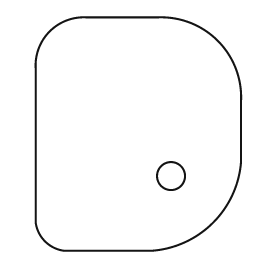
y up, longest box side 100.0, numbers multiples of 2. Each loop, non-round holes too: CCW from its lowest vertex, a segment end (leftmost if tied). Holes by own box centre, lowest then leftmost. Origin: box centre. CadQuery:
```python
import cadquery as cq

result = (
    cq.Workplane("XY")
    .moveTo(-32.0, -50.0)
    .lineTo(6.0, -50.0)
    .threePointArc((32.0, -38.0), (44.0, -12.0))
    .lineTo(44.0, 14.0)
    .threePointArc((34.0, 40.0), (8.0, 50.0))
    .lineTo(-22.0, 50.0)
    .threePointArc((-38.0, 44.0), (-44.0, 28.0))
    .lineTo(-44.0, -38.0)
    .threePointArc((-40.0, -46.0), (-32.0, -50.0))
    .close()
    .moveTo(14.0, -18.0)
    .circle(6.0)
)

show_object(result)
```